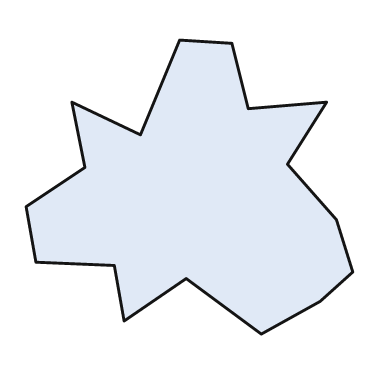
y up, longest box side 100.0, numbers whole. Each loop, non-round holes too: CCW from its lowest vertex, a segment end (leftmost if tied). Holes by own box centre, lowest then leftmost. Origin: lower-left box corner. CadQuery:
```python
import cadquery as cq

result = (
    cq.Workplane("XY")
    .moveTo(72.0, 0.0)
    .lineTo(90.0, 10.0)
    .lineTo(100.0, 19.0)
    .lineTo(95.0, 35.0)
    .lineTo(80.0, 52.0)
    .lineTo(92.0, 71.0)
    .lineTo(68.0, 69.0)
    .lineTo(63.0, 89.0)
    .lineTo(47.0, 90.0)
    .lineTo(35.0, 61.0)
    .lineTo(14.0, 71.0)
    .lineTo(18.0, 51.0)
    .lineTo(0.0, 39.0)
    .lineTo(3.0, 22.0)
    .lineTo(27.0, 21.0)
    .lineTo(30.0, 4.0)
    .lineTo(49.0, 17.0)
    .close()
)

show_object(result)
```